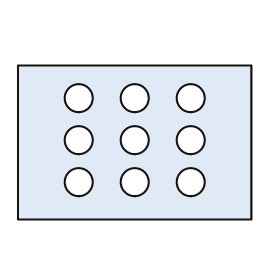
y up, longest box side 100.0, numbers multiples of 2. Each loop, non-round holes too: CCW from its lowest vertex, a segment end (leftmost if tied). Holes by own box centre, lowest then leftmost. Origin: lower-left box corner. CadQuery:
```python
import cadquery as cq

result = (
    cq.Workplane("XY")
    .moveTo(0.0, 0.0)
    .lineTo(100.0, 0.0)
    .lineTo(100.0, 66.0)
    .lineTo(0.0, 66.0)
    .close()
    .moveTo(26.0, 16.0)
    .circle(6.0)
    .moveTo(50.0, 16.0)
    .circle(6.0)
    .moveTo(74.0, 16.0)
    .circle(6.0)
    .moveTo(26.0, 34.0)
    .circle(6.0)
    .moveTo(50.0, 34.0)
    .circle(6.0)
    .moveTo(74.0, 34.0)
    .circle(6.0)
    .moveTo(26.0, 52.0)
    .circle(6.0)
    .moveTo(50.0, 52.0)
    .circle(6.0)
    .moveTo(74.0, 52.0)
    .circle(6.0)
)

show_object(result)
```